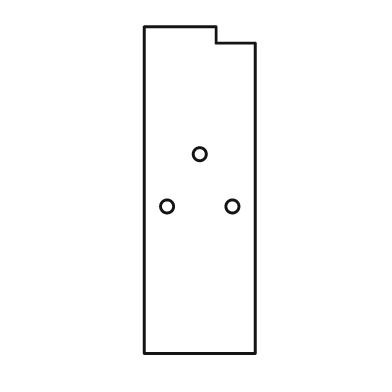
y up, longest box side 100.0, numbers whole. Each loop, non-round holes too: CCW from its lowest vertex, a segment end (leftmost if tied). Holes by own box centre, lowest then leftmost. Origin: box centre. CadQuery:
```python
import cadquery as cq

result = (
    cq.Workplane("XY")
    .moveTo(-17.0, -50.0)
    .lineTo(17.0, -50.0)
    .lineTo(17.0, 45.0)
    .lineTo(5.0, 45.0)
    .lineTo(5.0, 50.0)
    .lineTo(-17.0, 50.0)
    .close()
    .moveTo(-10.0, -5.0)
    .circle(2.0)
    .moveTo(10.0, -5.0)
    .circle(2.0)
    .moveTo(0.0, 11.0)
    .circle(2.0)
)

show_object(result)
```